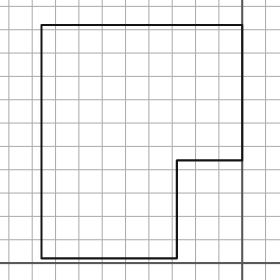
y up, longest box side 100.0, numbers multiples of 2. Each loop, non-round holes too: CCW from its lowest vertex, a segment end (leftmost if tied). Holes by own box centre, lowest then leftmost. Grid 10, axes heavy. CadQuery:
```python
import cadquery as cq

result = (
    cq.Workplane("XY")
    .moveTo(-86.0, 2.0)
    .lineTo(-28.0, 2.0)
    .lineTo(-28.0, 44.0)
    .lineTo(0.0, 44.0)
    .lineTo(0.0, 102.0)
    .lineTo(-86.0, 102.0)
    .close()
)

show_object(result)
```